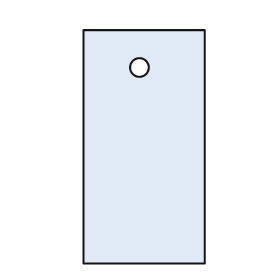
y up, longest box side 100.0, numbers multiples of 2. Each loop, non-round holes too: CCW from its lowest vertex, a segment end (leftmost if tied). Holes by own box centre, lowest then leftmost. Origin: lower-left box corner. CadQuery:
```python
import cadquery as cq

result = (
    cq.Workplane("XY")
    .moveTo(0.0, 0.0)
    .lineTo(52.0, 0.0)
    .lineTo(52.0, 100.0)
    .lineTo(0.0, 100.0)
    .close()
    .moveTo(24.0, 84.0)
    .circle(4.0)
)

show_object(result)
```